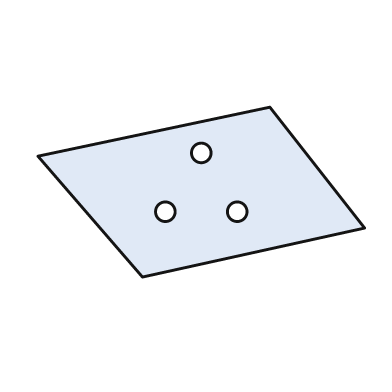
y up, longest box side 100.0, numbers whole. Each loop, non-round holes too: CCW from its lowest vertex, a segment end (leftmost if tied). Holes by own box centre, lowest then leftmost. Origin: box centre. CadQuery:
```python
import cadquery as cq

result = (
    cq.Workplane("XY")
    .moveTo(-18.0, -26.0)
    .lineTo(50.0, -11.0)
    .lineTo(21.0, 26.0)
    .lineTo(-50.0, 11.0)
    .close()
    .moveTo(-11.0, -6.0)
    .circle(3.0)
    .moveTo(11.0, -6.0)
    .circle(3.0)
    .moveTo(0.0, 12.0)
    .circle(3.0)
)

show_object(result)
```